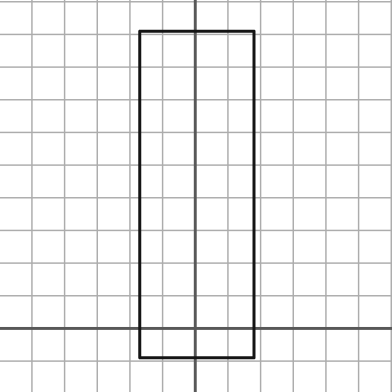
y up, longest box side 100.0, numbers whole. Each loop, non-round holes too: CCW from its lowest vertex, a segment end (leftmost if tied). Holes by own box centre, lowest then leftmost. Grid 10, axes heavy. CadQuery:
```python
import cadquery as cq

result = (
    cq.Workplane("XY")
    .moveTo(-17.0, -9.0)
    .lineTo(18.0, -9.0)
    .lineTo(18.0, 91.0)
    .lineTo(-17.0, 91.0)
    .close()
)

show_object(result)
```